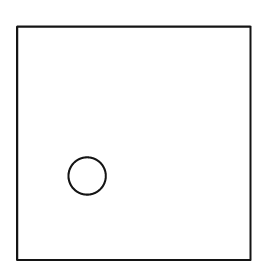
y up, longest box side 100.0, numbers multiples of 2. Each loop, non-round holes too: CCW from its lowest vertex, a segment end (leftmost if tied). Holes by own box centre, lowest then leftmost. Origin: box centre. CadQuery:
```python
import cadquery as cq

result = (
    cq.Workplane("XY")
    .moveTo(-50.0, -50.0)
    .lineTo(50.0, -50.0)
    .lineTo(50.0, 50.0)
    .lineTo(-50.0, 50.0)
    .close()
    .moveTo(-20.0, -14.0)
    .circle(8.0)
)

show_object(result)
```